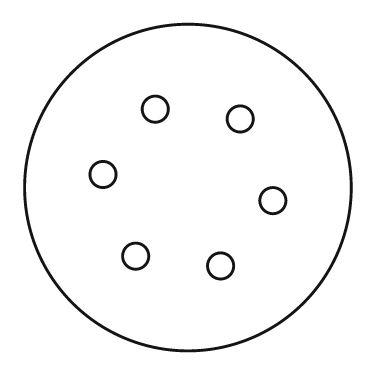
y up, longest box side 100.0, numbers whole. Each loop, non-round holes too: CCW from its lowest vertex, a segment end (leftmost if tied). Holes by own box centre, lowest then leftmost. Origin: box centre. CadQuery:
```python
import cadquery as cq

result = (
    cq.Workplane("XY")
    .moveTo(0.0, 0.0)
    .circle(50.0)
    .moveTo(10.0, -24.0)
    .circle(4.0)
    .moveTo(-16.0, -21.0)
    .circle(4.0)
    .moveTo(26.0, -4.0)
    .circle(4.0)
    .moveTo(-26.0, 4.0)
    .circle(4.0)
    .moveTo(16.0, 21.0)
    .circle(4.0)
    .moveTo(-10.0, 24.0)
    .circle(4.0)
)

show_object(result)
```